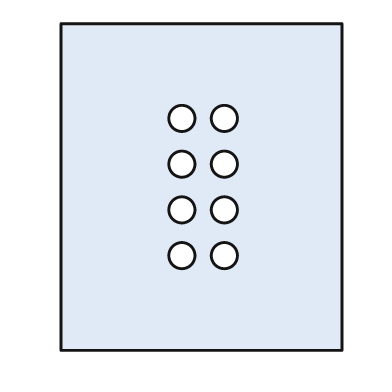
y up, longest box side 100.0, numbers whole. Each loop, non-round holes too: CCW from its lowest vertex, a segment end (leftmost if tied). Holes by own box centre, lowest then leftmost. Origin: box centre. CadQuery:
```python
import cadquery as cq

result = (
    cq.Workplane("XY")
    .moveTo(-43.0, -50.0)
    .lineTo(43.0, -50.0)
    .lineTo(43.0, 50.0)
    .lineTo(-43.0, 50.0)
    .close()
    .moveTo(-6.0, -21.0)
    .circle(4.0)
    .moveTo(7.0, -21.0)
    .circle(4.0)
    .moveTo(-6.0, -7.0)
    .circle(4.0)
    .moveTo(7.0, -7.0)
    .circle(4.0)
    .moveTo(-6.0, 7.0)
    .circle(4.0)
    .moveTo(7.0, 7.0)
    .circle(4.0)
    .moveTo(-6.0, 21.0)
    .circle(4.0)
    .moveTo(7.0, 21.0)
    .circle(4.0)
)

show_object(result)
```